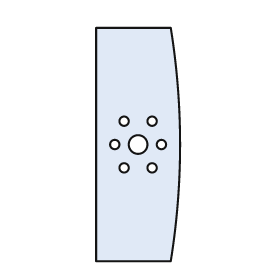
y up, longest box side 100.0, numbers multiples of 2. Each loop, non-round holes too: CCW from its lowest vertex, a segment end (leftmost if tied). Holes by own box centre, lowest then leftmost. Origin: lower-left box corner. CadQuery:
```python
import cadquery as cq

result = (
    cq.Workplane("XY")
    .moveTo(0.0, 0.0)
    .lineTo(32.0, 0.0)
    .threePointArc((36.0, 50.0), (32.0, 100.0))
    .lineTo(0.0, 100.0)
    .close()
    .moveTo(12.0, 40.0)
    .circle(2.0)
    .moveTo(24.0, 40.0)
    .circle(2.0)
    .moveTo(8.0, 50.0)
    .circle(2.0)
    .moveTo(18.0, 50.0)
    .circle(4.0)
    .moveTo(28.0, 50.0)
    .circle(2.0)
    .moveTo(12.0, 60.0)
    .circle(2.0)
    .moveTo(24.0, 60.0)
    .circle(2.0)
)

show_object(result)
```